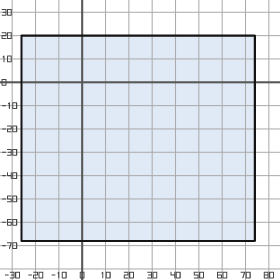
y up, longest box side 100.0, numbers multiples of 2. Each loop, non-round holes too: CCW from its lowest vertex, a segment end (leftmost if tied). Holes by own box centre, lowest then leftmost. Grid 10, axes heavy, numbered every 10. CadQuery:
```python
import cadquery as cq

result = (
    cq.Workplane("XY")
    .moveTo(-26.0, -68.0)
    .lineTo(74.0, -68.0)
    .lineTo(74.0, 20.0)
    .lineTo(-26.0, 20.0)
    .close()
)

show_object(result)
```